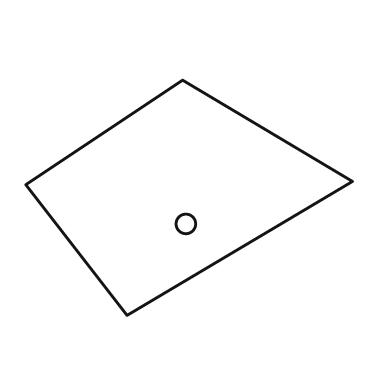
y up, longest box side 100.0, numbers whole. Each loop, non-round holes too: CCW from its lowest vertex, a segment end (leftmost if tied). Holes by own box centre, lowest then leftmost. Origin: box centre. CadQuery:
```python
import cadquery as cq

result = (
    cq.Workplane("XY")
    .moveTo(-19.0, -36.0)
    .lineTo(50.0, 5.0)
    .lineTo(-2.0, 36.0)
    .lineTo(-50.0, 4.0)
    .close()
    .moveTo(-1.0, -8.0)
    .circle(3.0)
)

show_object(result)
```